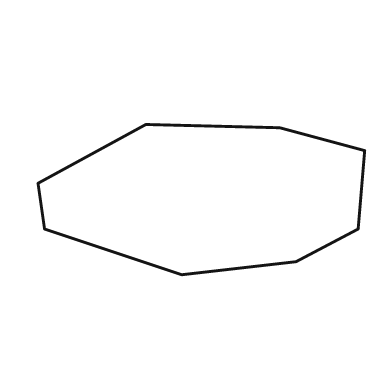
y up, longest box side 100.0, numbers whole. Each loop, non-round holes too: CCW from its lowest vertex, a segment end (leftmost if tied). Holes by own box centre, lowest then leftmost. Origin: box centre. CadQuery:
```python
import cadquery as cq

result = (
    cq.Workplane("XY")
    .moveTo(-6.0, -23.0)
    .lineTo(29.0, -19.0)
    .lineTo(48.0, -9.0)
    .lineTo(50.0, 15.0)
    .lineTo(24.0, 22.0)
    .lineTo(-17.0, 23.0)
    .lineTo(-50.0, 5.0)
    .lineTo(-48.0, -9.0)
    .close()
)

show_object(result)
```